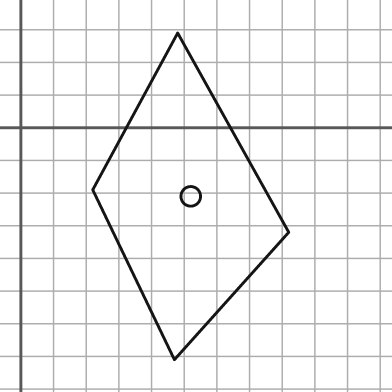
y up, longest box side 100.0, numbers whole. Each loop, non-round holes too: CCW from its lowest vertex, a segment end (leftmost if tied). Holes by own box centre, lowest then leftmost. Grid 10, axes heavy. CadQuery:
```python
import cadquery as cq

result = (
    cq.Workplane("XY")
    .moveTo(47.0, -71.0)
    .lineTo(82.0, -32.0)
    .lineTo(48.0, 29.0)
    .lineTo(22.0, -19.0)
    .close()
    .moveTo(52.0, -21.0)
    .circle(3.0)
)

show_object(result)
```